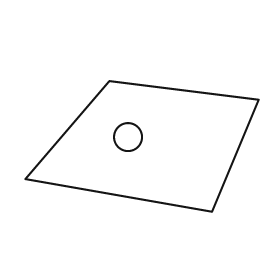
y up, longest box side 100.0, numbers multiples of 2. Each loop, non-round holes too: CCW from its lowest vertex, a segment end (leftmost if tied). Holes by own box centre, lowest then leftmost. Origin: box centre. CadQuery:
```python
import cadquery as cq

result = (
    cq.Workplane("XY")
    .moveTo(30.0, -28.0)
    .lineTo(50.0, 20.0)
    .lineTo(-14.0, 28.0)
    .lineTo(-50.0, -14.0)
    .close()
    .moveTo(-6.0, 4.0)
    .circle(6.0)
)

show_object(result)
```